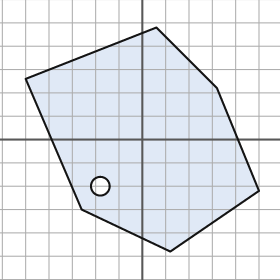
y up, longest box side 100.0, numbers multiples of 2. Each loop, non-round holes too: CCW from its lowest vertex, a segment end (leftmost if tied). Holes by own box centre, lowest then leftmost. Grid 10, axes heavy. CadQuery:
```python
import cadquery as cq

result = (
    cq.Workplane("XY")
    .moveTo(12.0, -48.0)
    .lineTo(50.0, -22.0)
    .lineTo(32.0, 22.0)
    .lineTo(6.0, 48.0)
    .lineTo(-50.0, 26.0)
    .lineTo(-26.0, -30.0)
    .close()
    .moveTo(-18.0, -20.0)
    .circle(4.0)
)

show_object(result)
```